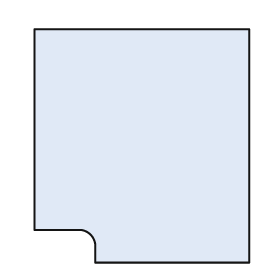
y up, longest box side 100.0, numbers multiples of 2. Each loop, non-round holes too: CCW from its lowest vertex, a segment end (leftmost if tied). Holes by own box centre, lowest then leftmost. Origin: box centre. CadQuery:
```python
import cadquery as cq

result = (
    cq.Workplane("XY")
    .moveTo(-20.0, -50.0)
    .lineTo(46.0, -50.0)
    .lineTo(46.0, 50.0)
    .lineTo(-46.0, 50.0)
    .lineTo(-46.0, -36.0)
    .lineTo(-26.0, -36.0)
    .threePointArc((-22.0, -38.0), (-20.0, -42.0))
    .close()
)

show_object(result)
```